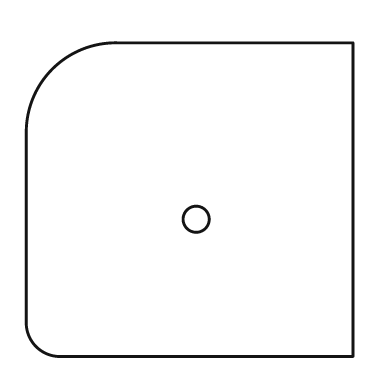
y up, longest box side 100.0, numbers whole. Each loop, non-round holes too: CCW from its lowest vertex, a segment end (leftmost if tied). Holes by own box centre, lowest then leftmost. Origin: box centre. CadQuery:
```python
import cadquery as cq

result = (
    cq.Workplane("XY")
    .moveTo(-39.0, -48.0)
    .lineTo(50.0, -48.0)
    .lineTo(50.0, 48.0)
    .lineTo(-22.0, 48.0)
    .threePointArc((-42.0, 40.0), (-50.0, 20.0))
    .lineTo(-50.0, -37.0)
    .threePointArc((-47.0, -45.0), (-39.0, -48.0))
    .close()
    .moveTo(2.0, -6.0)
    .circle(4.0)
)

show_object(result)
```